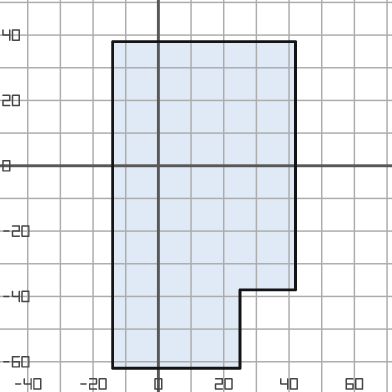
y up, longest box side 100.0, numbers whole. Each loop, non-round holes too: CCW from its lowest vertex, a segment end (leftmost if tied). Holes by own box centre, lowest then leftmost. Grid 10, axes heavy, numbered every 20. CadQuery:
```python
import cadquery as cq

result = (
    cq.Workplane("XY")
    .moveTo(-14.0, -62.0)
    .lineTo(25.0, -62.0)
    .lineTo(25.0, -38.0)
    .lineTo(42.0, -38.0)
    .lineTo(42.0, 38.0)
    .lineTo(-14.0, 38.0)
    .close()
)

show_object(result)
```